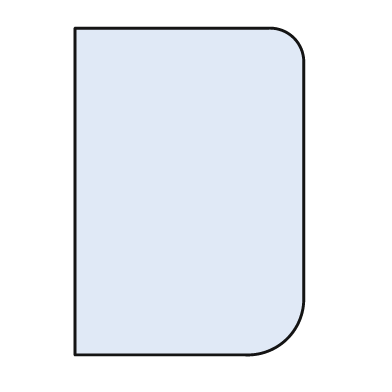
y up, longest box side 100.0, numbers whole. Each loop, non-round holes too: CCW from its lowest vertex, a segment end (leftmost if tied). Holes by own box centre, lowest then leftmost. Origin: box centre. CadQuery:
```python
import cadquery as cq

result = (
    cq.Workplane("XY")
    .moveTo(-35.0, -50.0)
    .lineTo(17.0, -50.0)
    .threePointArc((30.0, -45.0), (35.0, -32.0))
    .lineTo(35.0, 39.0)
    .threePointArc((32.0, 47.0), (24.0, 50.0))
    .lineTo(-35.0, 50.0)
    .close()
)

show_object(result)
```